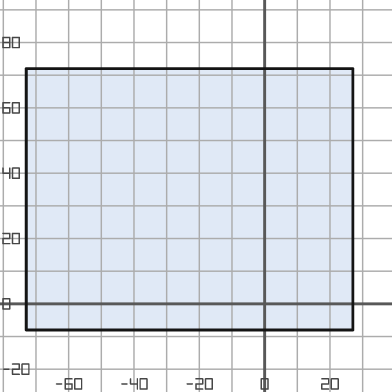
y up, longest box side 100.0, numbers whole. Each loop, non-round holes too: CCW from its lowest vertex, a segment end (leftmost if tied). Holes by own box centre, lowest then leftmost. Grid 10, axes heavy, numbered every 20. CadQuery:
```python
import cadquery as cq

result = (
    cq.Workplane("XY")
    .moveTo(-73.0, -8.0)
    .lineTo(27.0, -8.0)
    .lineTo(27.0, 72.0)
    .lineTo(-73.0, 72.0)
    .close()
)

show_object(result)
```